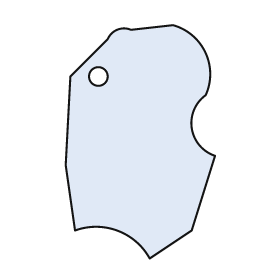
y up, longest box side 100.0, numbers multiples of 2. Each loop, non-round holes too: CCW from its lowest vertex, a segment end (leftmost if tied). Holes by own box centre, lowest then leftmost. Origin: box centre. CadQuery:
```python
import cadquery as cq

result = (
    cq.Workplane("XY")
    .moveTo(4.0, -50.0)
    .lineTo(22.0, -38.0)
    .lineTo(32.0, -6.0)
    .threePointArc((22.0, 6.0), (28.0, 20.0))
    .threePointArc((28.0, 38.0), (14.0, 50.0))
    .lineTo(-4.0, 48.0)
    .threePointArc((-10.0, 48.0), (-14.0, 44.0))
    .lineTo(-30.0, 28.0)
    .lineTo(-32.0, -10.0)
    .lineTo(-28.0, -38.0)
    .threePointArc((-10.0, -38.0), (4.0, -50.0))
    .close()
    .moveTo(-18.0, 28.0)
    .circle(4.0)
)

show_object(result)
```